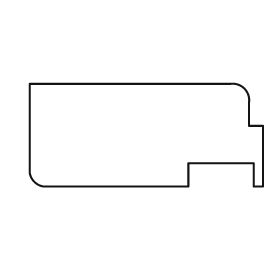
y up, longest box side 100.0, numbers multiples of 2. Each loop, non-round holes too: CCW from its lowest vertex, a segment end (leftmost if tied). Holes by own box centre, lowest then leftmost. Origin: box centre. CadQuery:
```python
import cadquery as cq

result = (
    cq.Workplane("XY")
    .moveTo(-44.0, -22.0)
    .lineTo(18.0, -22.0)
    .lineTo(18.0, -12.0)
    .lineTo(46.0, -12.0)
    .lineTo(46.0, -22.0)
    .lineTo(50.0, -22.0)
    .lineTo(50.0, 4.0)
    .lineTo(44.0, 4.0)
    .lineTo(44.0, 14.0)
    .threePointArc((42.0, 20.0), (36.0, 22.0))
    .lineTo(-50.0, 22.0)
    .lineTo(-50.0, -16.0)
    .threePointArc((-48.0, -20.0), (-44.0, -22.0))
    .close()
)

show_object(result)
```